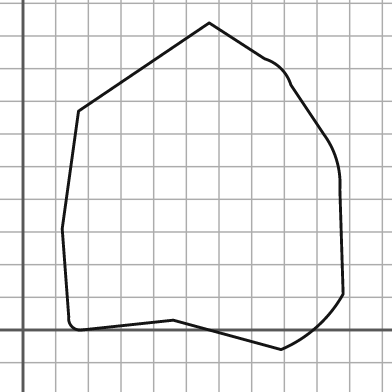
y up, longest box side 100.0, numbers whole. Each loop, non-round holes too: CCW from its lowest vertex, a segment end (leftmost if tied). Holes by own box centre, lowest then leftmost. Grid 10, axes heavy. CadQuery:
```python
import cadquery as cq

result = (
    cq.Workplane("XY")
    .moveTo(79.0, -6.0)
    .threePointArc((90.0, 1.0), (98.0, 11.0))
    .lineTo(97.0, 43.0)
    .threePointArc((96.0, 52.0), (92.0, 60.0))
    .lineTo(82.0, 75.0)
    .threePointArc((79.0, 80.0), (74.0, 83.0))
    .lineTo(57.0, 94.0)
    .lineTo(17.0, 67.0)
    .lineTo(12.0, 31.0)
    .lineTo(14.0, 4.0)
    .threePointArc((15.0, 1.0), (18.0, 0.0))
    .lineTo(46.0, 3.0)
    .close()
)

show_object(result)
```